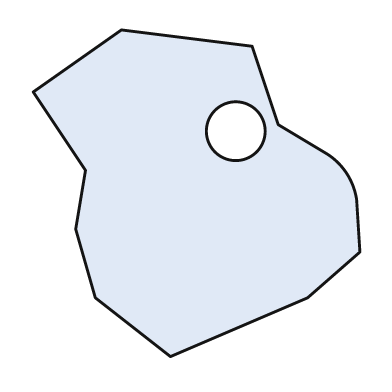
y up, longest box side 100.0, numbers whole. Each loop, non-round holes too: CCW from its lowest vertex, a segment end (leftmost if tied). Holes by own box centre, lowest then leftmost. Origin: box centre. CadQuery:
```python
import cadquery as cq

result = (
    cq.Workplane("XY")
    .moveTo(-8.0, -50.0)
    .lineTo(34.0, -32.0)
    .lineTo(50.0, -18.0)
    .lineTo(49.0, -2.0)
    .threePointArc((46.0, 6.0), (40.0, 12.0))
    .lineTo(25.0, 21.0)
    .lineTo(17.0, 45.0)
    .lineTo(-23.0, 50.0)
    .lineTo(-50.0, 31.0)
    .lineTo(-34.0, 7.0)
    .lineTo(-37.0, -11.0)
    .lineTo(-31.0, -32.0)
    .close()
    .moveTo(12.0, 19.0)
    .circle(9.0)
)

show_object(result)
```